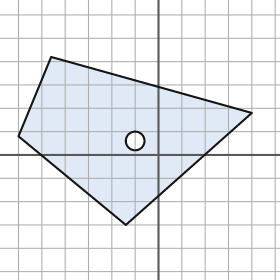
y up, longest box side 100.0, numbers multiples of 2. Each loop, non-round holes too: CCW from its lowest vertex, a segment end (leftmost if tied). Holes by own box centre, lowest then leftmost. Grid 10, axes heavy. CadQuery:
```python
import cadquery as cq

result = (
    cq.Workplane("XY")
    .moveTo(-14.0, -30.0)
    .lineTo(40.0, 18.0)
    .lineTo(-46.0, 42.0)
    .lineTo(-60.0, 8.0)
    .close()
    .moveTo(-10.0, 6.0)
    .circle(4.0)
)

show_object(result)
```